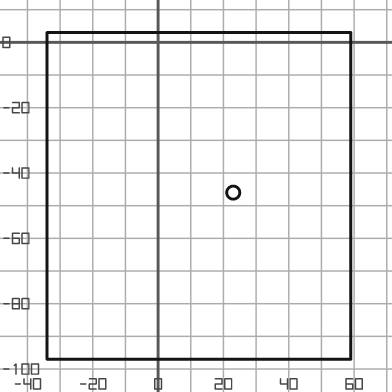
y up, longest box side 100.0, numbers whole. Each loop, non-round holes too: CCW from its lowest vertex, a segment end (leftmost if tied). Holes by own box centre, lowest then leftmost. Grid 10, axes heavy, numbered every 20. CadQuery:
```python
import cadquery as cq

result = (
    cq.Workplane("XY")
    .moveTo(-34.0, -97.0)
    .lineTo(59.0, -97.0)
    .lineTo(59.0, 3.0)
    .lineTo(-34.0, 3.0)
    .close()
    .moveTo(23.0, -46.0)
    .circle(2.0)
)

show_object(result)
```